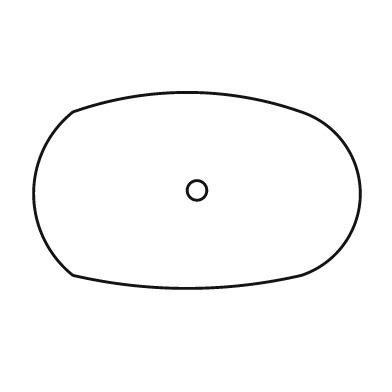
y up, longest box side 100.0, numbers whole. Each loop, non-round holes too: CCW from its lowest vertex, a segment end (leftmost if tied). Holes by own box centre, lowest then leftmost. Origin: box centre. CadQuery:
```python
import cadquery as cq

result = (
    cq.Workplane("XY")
    .moveTo(-38.0, -26.0)
    .threePointArc((-3.0, -30.0), (32.0, -26.0))
    .threePointArc((50.0, -1.0), (32.0, 24.0))
    .threePointArc((-3.0, 30.0), (-38.0, 24.0))
    .threePointArc((-50.0, -1.0), (-38.0, -26.0))
    .close()
    .moveTo(0.0, 0.0)
    .circle(3.0)
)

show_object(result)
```